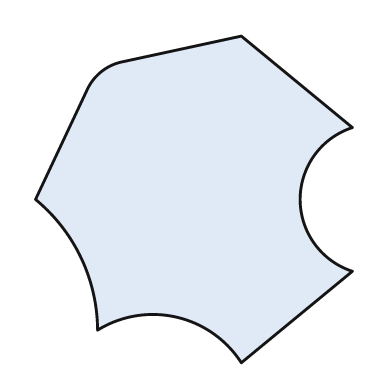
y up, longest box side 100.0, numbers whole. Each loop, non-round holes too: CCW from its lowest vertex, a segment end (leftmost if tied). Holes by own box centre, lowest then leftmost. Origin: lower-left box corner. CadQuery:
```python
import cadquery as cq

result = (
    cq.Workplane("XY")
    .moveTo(63.0, 0.0)
    .lineTo(97.0, 28.0)
    .threePointArc((81.0, 50.0), (97.0, 72.0))
    .lineTo(63.0, 100.0)
    .lineTo(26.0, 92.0)
    .threePointArc((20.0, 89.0), (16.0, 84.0))
    .lineTo(0.0, 50.0)
    .threePointArc((14.0, 32.0), (19.0, 10.0))
    .threePointArc((43.0, 14.0), (63.0, 0.0))
    .close()
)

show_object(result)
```